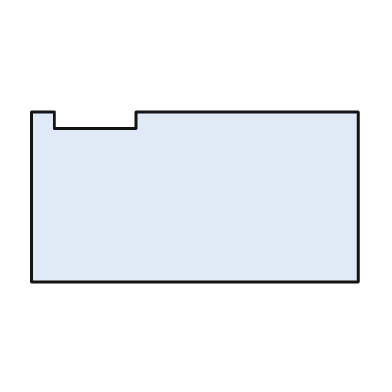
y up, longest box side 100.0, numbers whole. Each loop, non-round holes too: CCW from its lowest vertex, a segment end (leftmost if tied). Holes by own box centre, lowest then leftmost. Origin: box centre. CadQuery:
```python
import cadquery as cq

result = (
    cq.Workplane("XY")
    .moveTo(-50.0, -26.0)
    .lineTo(50.0, -26.0)
    .lineTo(50.0, 26.0)
    .lineTo(-18.0, 26.0)
    .lineTo(-18.0, 21.0)
    .lineTo(-43.0, 21.0)
    .lineTo(-43.0, 26.0)
    .lineTo(-50.0, 26.0)
    .close()
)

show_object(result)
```